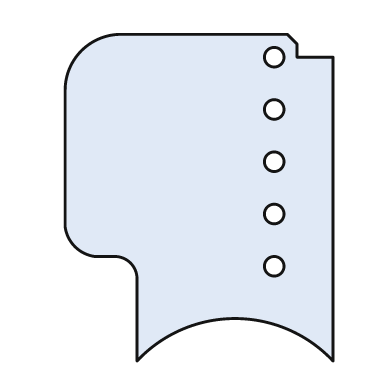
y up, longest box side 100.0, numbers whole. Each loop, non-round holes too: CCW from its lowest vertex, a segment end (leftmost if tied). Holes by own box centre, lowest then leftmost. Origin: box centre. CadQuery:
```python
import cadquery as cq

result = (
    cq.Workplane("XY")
    .moveTo(-19.0, -50.0)
    .threePointArc((11.0, -37.0), (41.0, -50.0))
    .lineTo(41.0, 43.0)
    .lineTo(30.0, 43.0)
    .lineTo(30.0, 47.0)
    .lineTo(27.0, 50.0)
    .lineTo(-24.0, 50.0)
    .threePointArc((-36.0, 45.0), (-41.0, 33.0))
    .lineTo(-41.0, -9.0)
    .threePointArc((-38.0, -15.0), (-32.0, -18.0))
    .lineTo(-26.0, -18.0)
    .threePointArc((-21.0, -20.0), (-19.0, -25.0))
    .close()
    .moveTo(23.0, -21.0)
    .circle(3.0)
    .moveTo(23.0, -5.0)
    .circle(3.0)
    .moveTo(23.0, 11.0)
    .circle(3.0)
    .moveTo(23.0, 27.0)
    .circle(3.0)
    .moveTo(23.0, 43.0)
    .circle(3.0)
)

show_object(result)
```